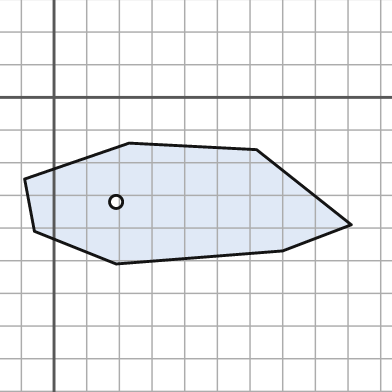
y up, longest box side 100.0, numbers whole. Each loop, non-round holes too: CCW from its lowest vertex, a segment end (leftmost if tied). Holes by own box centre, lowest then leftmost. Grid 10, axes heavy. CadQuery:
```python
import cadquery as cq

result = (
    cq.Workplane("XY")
    .moveTo(19.0, -51.0)
    .lineTo(70.0, -47.0)
    .lineTo(91.0, -39.0)
    .lineTo(62.0, -16.0)
    .lineTo(23.0, -14.0)
    .lineTo(-9.0, -25.0)
    .lineTo(-6.0, -41.0)
    .close()
    .moveTo(19.0, -32.0)
    .circle(2.0)
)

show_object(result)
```